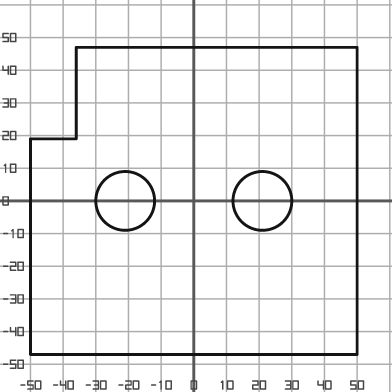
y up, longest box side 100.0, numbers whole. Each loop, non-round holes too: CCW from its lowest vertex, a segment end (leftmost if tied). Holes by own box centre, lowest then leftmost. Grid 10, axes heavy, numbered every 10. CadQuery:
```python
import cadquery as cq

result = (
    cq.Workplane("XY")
    .moveTo(-50.0, -47.0)
    .lineTo(50.0, -47.0)
    .lineTo(50.0, 47.0)
    .lineTo(-36.0, 47.0)
    .lineTo(-36.0, 19.0)
    .lineTo(-50.0, 19.0)
    .close()
    .moveTo(-21.0, 0.0)
    .circle(9.0)
    .moveTo(21.0, 0.0)
    .circle(9.0)
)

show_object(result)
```